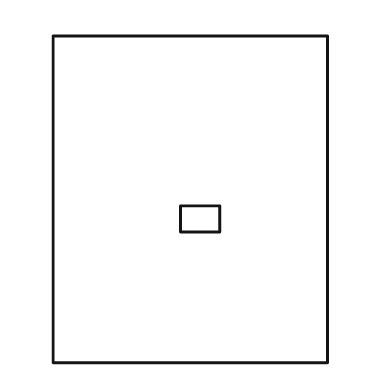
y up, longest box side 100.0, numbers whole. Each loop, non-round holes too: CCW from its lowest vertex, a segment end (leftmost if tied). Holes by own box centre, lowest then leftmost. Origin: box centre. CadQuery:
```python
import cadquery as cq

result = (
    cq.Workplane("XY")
    .moveTo(-42.0, -50.0)
    .lineTo(42.0, -50.0)
    .lineTo(42.0, 50.0)
    .lineTo(-42.0, 50.0)
    .close()
    .moveTo(-3.0, -10.0)
    .lineTo(9.0, -10.0)
    .lineTo(9.0, -2.0)
    .lineTo(-3.0, -2.0)
    .close()
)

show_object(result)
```